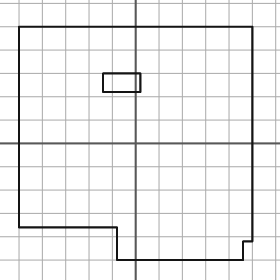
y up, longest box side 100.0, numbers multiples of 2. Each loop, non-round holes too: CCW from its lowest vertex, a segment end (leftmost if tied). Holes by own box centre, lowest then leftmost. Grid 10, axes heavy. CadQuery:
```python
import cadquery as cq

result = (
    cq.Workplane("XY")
    .moveTo(-8.0, -50.0)
    .lineTo(46.0, -50.0)
    .lineTo(46.0, -42.0)
    .lineTo(50.0, -42.0)
    .lineTo(50.0, 50.0)
    .lineTo(-50.0, 50.0)
    .lineTo(-50.0, -36.0)
    .lineTo(-8.0, -36.0)
    .close()
    .moveTo(-14.0, 22.0)
    .lineTo(2.0, 22.0)
    .lineTo(2.0, 30.0)
    .lineTo(-14.0, 30.0)
    .close()
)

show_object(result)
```